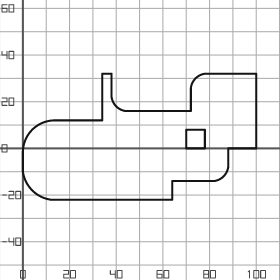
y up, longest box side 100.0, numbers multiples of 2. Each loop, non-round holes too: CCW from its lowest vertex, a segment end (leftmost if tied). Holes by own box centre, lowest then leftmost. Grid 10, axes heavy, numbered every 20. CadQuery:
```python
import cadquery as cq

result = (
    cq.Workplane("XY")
    .moveTo(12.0, -22.0)
    .lineTo(64.0, -22.0)
    .lineTo(64.0, -14.0)
    .lineTo(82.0, -14.0)
    .threePointArc((86.0, -12.0), (88.0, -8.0))
    .lineTo(88.0, 0.0)
    .lineTo(100.0, 0.0)
    .lineTo(100.0, 32.0)
    .lineTo(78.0, 32.0)
    .threePointArc((74.0, 30.0), (72.0, 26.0))
    .lineTo(72.0, 16.0)
    .lineTo(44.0, 16.0)
    .threePointArc((40.0, 18.0), (38.0, 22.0))
    .lineTo(38.0, 32.0)
    .lineTo(34.0, 32.0)
    .lineTo(34.0, 12.0)
    .lineTo(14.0, 12.0)
    .threePointArc((4.0, 8.0), (0.0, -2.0))
    .lineTo(0.0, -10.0)
    .threePointArc((4.0, -18.0), (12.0, -22.0))
    .close()
    .moveTo(70.0, 0.0)
    .lineTo(78.0, 0.0)
    .lineTo(78.0, 8.0)
    .lineTo(70.0, 8.0)
    .close()
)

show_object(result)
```